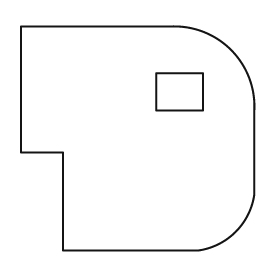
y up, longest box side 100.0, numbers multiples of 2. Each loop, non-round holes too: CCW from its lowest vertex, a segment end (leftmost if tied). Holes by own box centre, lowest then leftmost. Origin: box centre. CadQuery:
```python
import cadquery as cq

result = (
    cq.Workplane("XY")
    .moveTo(-32.0, -48.0)
    .lineTo(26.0, -48.0)
    .threePointArc((42.0, -40.0), (50.0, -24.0))
    .lineTo(50.0, 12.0)
    .threePointArc((40.0, 38.0), (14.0, 48.0))
    .lineTo(-50.0, 48.0)
    .lineTo(-50.0, -6.0)
    .lineTo(-32.0, -6.0)
    .close()
    .moveTo(8.0, 12.0)
    .lineTo(28.0, 12.0)
    .lineTo(28.0, 28.0)
    .lineTo(8.0, 28.0)
    .close()
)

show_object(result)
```